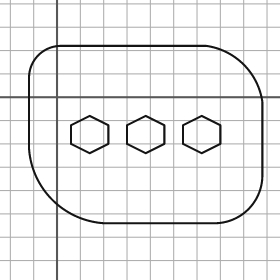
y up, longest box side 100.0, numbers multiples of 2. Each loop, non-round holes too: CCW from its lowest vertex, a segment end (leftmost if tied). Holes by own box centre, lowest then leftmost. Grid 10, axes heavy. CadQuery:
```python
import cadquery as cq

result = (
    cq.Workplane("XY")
    .moveTo(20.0, -54.0)
    .lineTo(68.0, -54.0)
    .threePointArc((82.0, -48.0), (88.0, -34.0))
    .lineTo(88.0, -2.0)
    .threePointArc((80.0, 14.0), (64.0, 22.0))
    .lineTo(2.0, 22.0)
    .threePointArc((-8.0, 18.0), (-12.0, 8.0))
    .lineTo(-12.0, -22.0)
    .threePointArc((-2.0, -44.0), (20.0, -54.0))
    .close()
    .moveTo(14.0, -24.0)
    .lineTo(22.0, -20.0)
    .lineTo(22.0, -12.0)
    .lineTo(14.0, -8.0)
    .lineTo(6.0, -12.0)
    .lineTo(6.0, -20.0)
    .close()
    .moveTo(38.0, -24.0)
    .lineTo(46.0, -20.0)
    .lineTo(46.0, -12.0)
    .lineTo(38.0, -8.0)
    .lineTo(30.0, -12.0)
    .lineTo(30.0, -20.0)
    .close()
    .moveTo(62.0, -24.0)
    .lineTo(70.0, -20.0)
    .lineTo(70.0, -12.0)
    .lineTo(62.0, -8.0)
    .lineTo(54.0, -12.0)
    .lineTo(54.0, -20.0)
    .close()
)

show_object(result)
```